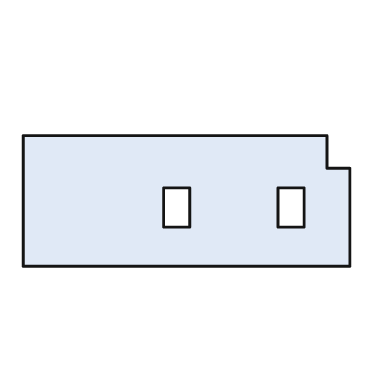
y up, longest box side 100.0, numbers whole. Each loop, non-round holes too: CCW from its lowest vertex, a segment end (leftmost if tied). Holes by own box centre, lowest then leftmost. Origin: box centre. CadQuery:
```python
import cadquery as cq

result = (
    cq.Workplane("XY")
    .moveTo(-50.0, -20.0)
    .lineTo(50.0, -20.0)
    .lineTo(50.0, 10.0)
    .lineTo(43.0, 10.0)
    .lineTo(43.0, 20.0)
    .lineTo(-50.0, 20.0)
    .close()
    .moveTo(-7.0, -8.0)
    .lineTo(1.0, -8.0)
    .lineTo(1.0, 4.0)
    .lineTo(-7.0, 4.0)
    .close()
    .moveTo(28.0, -8.0)
    .lineTo(36.0, -8.0)
    .lineTo(36.0, 4.0)
    .lineTo(28.0, 4.0)
    .close()
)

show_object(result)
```